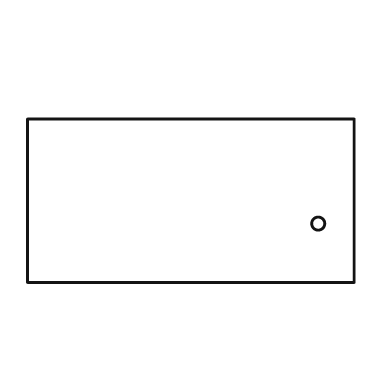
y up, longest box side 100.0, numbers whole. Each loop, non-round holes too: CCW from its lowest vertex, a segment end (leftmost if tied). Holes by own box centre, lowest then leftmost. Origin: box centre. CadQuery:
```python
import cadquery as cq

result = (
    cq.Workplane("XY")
    .moveTo(-50.0, -25.0)
    .lineTo(50.0, -25.0)
    .lineTo(50.0, 25.0)
    .lineTo(-50.0, 25.0)
    .close()
    .moveTo(39.0, -7.0)
    .circle(2.0)
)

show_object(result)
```